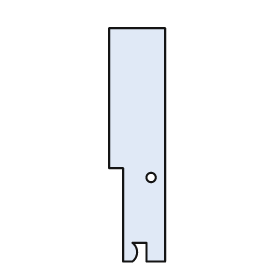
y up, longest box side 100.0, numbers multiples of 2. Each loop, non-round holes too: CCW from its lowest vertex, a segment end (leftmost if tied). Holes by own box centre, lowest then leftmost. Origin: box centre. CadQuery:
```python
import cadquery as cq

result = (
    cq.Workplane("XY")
    .moveTo(-6.0, -50.0)
    .lineTo(-2.0, -50.0)
    .threePointArc((0.0, -46.0), (-2.0, -42.0))
    .lineTo(4.0, -42.0)
    .lineTo(4.0, -50.0)
    .lineTo(12.0, -50.0)
    .lineTo(12.0, 50.0)
    .lineTo(-12.0, 50.0)
    .lineTo(-12.0, -10.0)
    .lineTo(-6.0, -10.0)
    .close()
    .moveTo(6.0, -14.0)
    .circle(2.0)
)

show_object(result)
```